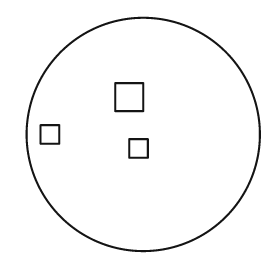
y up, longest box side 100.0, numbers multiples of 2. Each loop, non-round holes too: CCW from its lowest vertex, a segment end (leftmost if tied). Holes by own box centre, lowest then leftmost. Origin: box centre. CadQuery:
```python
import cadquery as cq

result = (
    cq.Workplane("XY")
    .moveTo(0.0, 0.0)
    .circle(50.0)
    .moveTo(-6.0, -10.0)
    .lineTo(2.0, -10.0)
    .lineTo(2.0, -2.0)
    .lineTo(-6.0, -2.0)
    .close()
    .moveTo(-44.0, -4.0)
    .lineTo(-36.0, -4.0)
    .lineTo(-36.0, 4.0)
    .lineTo(-44.0, 4.0)
    .close()
    .moveTo(-12.0, 10.0)
    .lineTo(0.0, 10.0)
    .lineTo(0.0, 22.0)
    .lineTo(-12.0, 22.0)
    .close()
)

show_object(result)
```